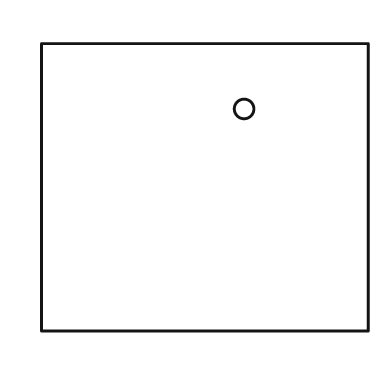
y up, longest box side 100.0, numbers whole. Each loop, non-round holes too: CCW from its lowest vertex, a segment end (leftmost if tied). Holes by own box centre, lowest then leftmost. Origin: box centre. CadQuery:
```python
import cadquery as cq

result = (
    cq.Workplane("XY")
    .moveTo(-50.0, -44.0)
    .lineTo(50.0, -44.0)
    .lineTo(50.0, 44.0)
    .lineTo(-50.0, 44.0)
    .close()
    .moveTo(12.0, 24.0)
    .circle(3.0)
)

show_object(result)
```